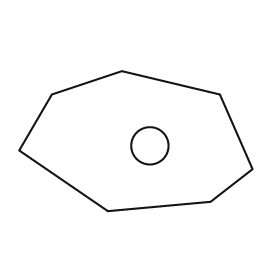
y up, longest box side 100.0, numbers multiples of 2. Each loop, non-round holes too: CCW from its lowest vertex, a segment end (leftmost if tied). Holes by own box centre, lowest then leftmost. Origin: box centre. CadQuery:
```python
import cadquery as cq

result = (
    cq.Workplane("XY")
    .moveTo(-12.0, -30.0)
    .lineTo(32.0, -26.0)
    .lineTo(50.0, -12.0)
    .lineTo(36.0, 20.0)
    .lineTo(-6.0, 30.0)
    .lineTo(-36.0, 20.0)
    .lineTo(-50.0, -4.0)
    .close()
    .moveTo(6.0, -2.0)
    .circle(8.0)
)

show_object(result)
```